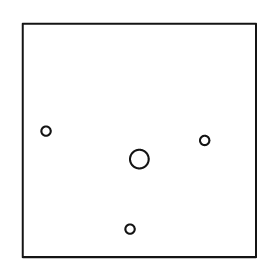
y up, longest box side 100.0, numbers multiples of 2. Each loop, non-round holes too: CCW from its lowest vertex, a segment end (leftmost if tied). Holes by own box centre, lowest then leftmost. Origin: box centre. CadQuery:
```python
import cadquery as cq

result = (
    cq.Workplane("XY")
    .moveTo(-50.0, -50.0)
    .lineTo(50.0, -50.0)
    .lineTo(50.0, 50.0)
    .lineTo(-50.0, 50.0)
    .close()
    .moveTo(-4.0, -38.0)
    .circle(2.0)
    .moveTo(0.0, -8.0)
    .circle(4.0)
    .moveTo(28.0, 0.0)
    .circle(2.0)
    .moveTo(-40.0, 4.0)
    .circle(2.0)
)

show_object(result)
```